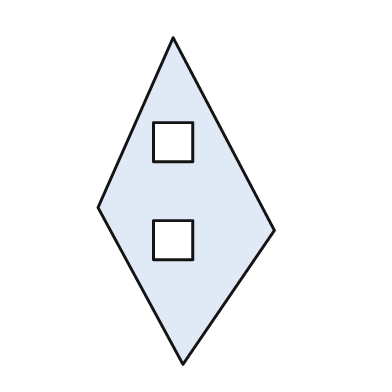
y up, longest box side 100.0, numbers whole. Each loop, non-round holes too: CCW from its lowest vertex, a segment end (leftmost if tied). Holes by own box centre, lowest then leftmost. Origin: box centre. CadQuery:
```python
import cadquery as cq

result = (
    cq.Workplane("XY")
    .moveTo(-1.0, -50.0)
    .lineTo(27.0, -9.0)
    .lineTo(-4.0, 50.0)
    .lineTo(-27.0, -2.0)
    .close()
    .moveTo(-10.0, -18.0)
    .lineTo(2.0, -18.0)
    .lineTo(2.0, -6.0)
    .lineTo(-10.0, -6.0)
    .close()
    .moveTo(-10.0, 12.0)
    .lineTo(2.0, 12.0)
    .lineTo(2.0, 24.0)
    .lineTo(-10.0, 24.0)
    .close()
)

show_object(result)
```